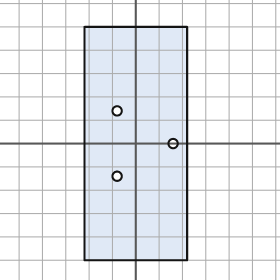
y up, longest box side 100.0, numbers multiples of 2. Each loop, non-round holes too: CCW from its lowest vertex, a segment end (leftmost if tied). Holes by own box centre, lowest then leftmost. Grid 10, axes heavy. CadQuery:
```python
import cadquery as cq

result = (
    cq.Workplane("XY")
    .moveTo(-22.0, -50.0)
    .lineTo(22.0, -50.0)
    .lineTo(22.0, 50.0)
    .lineTo(-22.0, 50.0)
    .close()
    .moveTo(-8.0, -14.0)
    .circle(2.0)
    .moveTo(16.0, 0.0)
    .circle(2.0)
    .moveTo(-8.0, 14.0)
    .circle(2.0)
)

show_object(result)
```